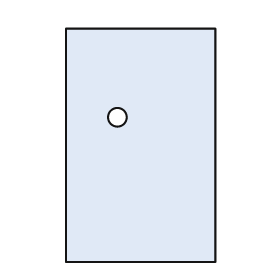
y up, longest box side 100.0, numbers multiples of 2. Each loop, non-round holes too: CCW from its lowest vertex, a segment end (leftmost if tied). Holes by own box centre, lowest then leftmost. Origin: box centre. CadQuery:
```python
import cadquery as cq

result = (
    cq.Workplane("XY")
    .moveTo(-32.0, -50.0)
    .lineTo(32.0, -50.0)
    .lineTo(32.0, 50.0)
    .lineTo(-32.0, 50.0)
    .close()
    .moveTo(-10.0, 12.0)
    .circle(4.0)
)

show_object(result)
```